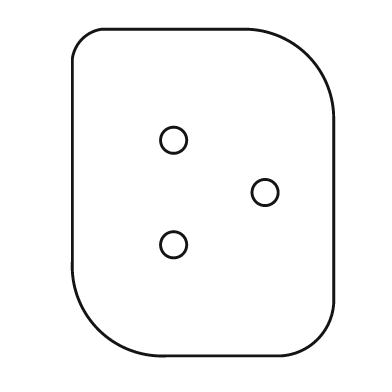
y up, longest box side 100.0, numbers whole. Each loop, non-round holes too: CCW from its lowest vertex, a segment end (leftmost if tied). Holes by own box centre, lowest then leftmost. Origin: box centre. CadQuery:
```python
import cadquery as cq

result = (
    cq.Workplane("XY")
    .moveTo(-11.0, -50.0)
    .lineTo(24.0, -50.0)
    .threePointArc((35.0, -45.0), (40.0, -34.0))
    .lineTo(40.0, 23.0)
    .threePointArc((32.0, 42.0), (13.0, 50.0))
    .lineTo(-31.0, 50.0)
    .threePointArc((-37.0, 47.0), (-40.0, 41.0))
    .lineTo(-40.0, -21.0)
    .threePointArc((-32.0, -42.0), (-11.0, -50.0))
    .close()
    .moveTo(-9.0, -16.0)
    .circle(4.0)
    .moveTo(19.0, 0.0)
    .circle(4.0)
    .moveTo(-9.0, 16.0)
    .circle(4.0)
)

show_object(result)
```